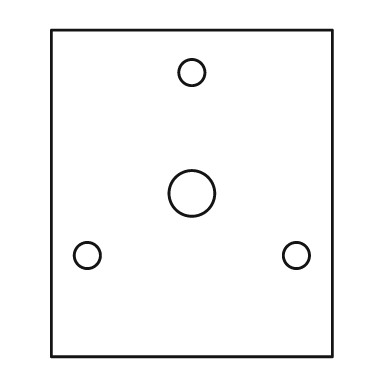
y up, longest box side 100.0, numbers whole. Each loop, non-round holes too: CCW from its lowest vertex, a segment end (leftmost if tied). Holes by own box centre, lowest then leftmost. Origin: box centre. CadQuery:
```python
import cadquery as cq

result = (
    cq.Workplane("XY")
    .moveTo(-43.0, -50.0)
    .lineTo(43.0, -50.0)
    .lineTo(43.0, 50.0)
    .lineTo(-43.0, 50.0)
    .close()
    .moveTo(-32.0, -19.0)
    .circle(4.0)
    .moveTo(32.0, -19.0)
    .circle(4.0)
    .moveTo(0.0, 0.0)
    .circle(7.0)
    .moveTo(0.0, 37.0)
    .circle(4.0)
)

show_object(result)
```